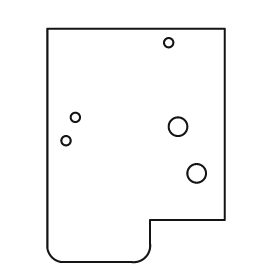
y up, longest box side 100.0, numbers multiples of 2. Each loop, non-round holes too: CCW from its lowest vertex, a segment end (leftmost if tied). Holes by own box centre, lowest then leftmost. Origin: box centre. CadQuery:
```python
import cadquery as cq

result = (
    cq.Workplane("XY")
    .moveTo(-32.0, -50.0)
    .lineTo(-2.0, -50.0)
    .threePointArc((4.0, -48.0), (6.0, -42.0))
    .lineTo(6.0, -32.0)
    .lineTo(38.0, -32.0)
    .lineTo(38.0, 50.0)
    .lineTo(-38.0, 50.0)
    .lineTo(-38.0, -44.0)
    .threePointArc((-36.0, -48.0), (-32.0, -50.0))
    .close()
    .moveTo(26.0, -12.0)
    .circle(4.0)
    .moveTo(-30.0, 2.0)
    .circle(2.0)
    .moveTo(18.0, 8.0)
    .circle(4.0)
    .moveTo(-26.0, 12.0)
    .circle(2.0)
    .moveTo(14.0, 44.0)
    .circle(2.0)
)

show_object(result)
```